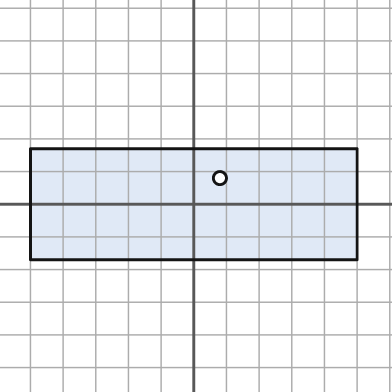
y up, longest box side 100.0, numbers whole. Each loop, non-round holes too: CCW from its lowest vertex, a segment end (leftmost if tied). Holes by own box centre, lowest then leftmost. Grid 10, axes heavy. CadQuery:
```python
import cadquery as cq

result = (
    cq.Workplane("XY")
    .moveTo(-50.0, -17.0)
    .lineTo(50.0, -17.0)
    .lineTo(50.0, 17.0)
    .lineTo(-50.0, 17.0)
    .close()
    .moveTo(8.0, 8.0)
    .circle(2.0)
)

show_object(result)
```